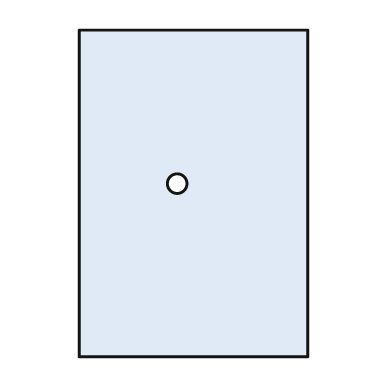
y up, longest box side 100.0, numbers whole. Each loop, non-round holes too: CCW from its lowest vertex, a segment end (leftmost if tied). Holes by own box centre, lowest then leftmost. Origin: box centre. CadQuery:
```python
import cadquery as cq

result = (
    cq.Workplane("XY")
    .moveTo(-35.0, -50.0)
    .lineTo(35.0, -50.0)
    .lineTo(35.0, 50.0)
    .lineTo(-35.0, 50.0)
    .close()
    .moveTo(-5.0, 3.0)
    .circle(3.0)
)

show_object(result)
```